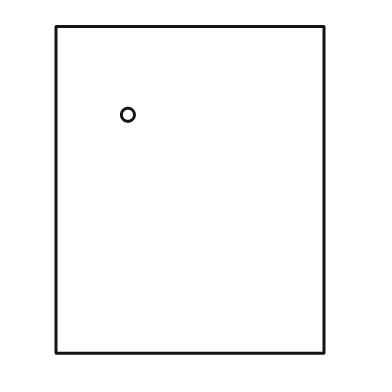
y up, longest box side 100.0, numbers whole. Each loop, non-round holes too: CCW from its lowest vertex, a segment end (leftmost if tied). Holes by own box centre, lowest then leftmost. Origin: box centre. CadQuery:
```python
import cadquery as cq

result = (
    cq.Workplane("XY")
    .moveTo(-41.0, -50.0)
    .lineTo(41.0, -50.0)
    .lineTo(41.0, 50.0)
    .lineTo(-41.0, 50.0)
    .close()
    .moveTo(-19.0, 23.0)
    .circle(2.0)
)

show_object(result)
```